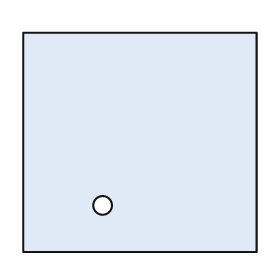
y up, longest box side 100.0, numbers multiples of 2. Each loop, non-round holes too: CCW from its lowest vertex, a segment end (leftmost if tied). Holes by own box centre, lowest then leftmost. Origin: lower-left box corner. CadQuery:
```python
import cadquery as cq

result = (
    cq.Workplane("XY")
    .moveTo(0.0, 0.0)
    .lineTo(100.0, 0.0)
    .lineTo(100.0, 94.0)
    .lineTo(0.0, 94.0)
    .close()
    .moveTo(34.0, 20.0)
    .circle(4.0)
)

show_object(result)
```